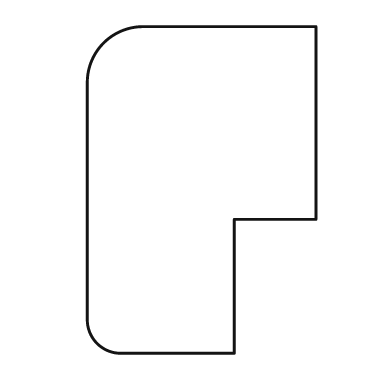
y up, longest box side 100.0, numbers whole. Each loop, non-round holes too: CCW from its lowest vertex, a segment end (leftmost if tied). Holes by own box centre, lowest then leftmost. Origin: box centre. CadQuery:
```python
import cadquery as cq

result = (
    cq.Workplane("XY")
    .moveTo(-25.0, -50.0)
    .lineTo(10.0, -50.0)
    .lineTo(10.0, -9.0)
    .lineTo(35.0, -9.0)
    .lineTo(35.0, 50.0)
    .lineTo(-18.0, 50.0)
    .threePointArc((-30.0, 45.0), (-35.0, 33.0))
    .lineTo(-35.0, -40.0)
    .threePointArc((-32.0, -47.0), (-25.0, -50.0))
    .close()
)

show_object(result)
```